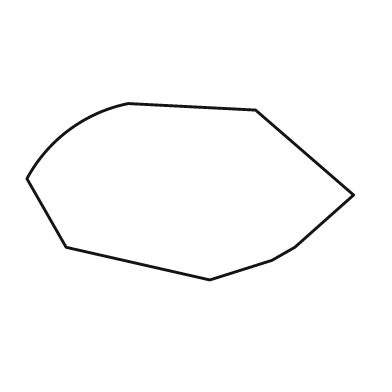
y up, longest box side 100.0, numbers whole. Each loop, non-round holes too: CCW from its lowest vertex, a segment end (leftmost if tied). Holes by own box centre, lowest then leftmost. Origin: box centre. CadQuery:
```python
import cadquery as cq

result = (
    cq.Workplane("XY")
    .moveTo(6.0, -27.0)
    .lineTo(25.0, -21.0)
    .lineTo(32.0, -17.0)
    .lineTo(50.0, -1.0)
    .lineTo(20.0, 25.0)
    .lineTo(-19.0, 27.0)
    .threePointArc((-37.0, 19.0), (-50.0, 4.0))
    .lineTo(-38.0, -17.0)
    .close()
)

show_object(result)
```